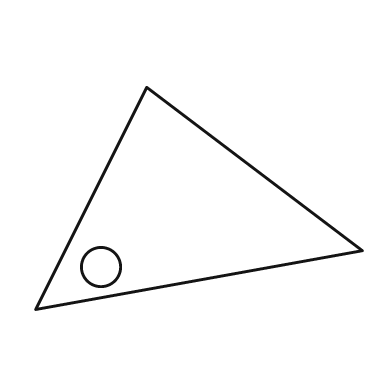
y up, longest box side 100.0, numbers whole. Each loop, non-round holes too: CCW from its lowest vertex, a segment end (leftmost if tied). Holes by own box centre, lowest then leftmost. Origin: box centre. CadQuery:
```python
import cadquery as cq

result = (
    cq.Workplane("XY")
    .moveTo(-50.0, -34.0)
    .lineTo(50.0, -16.0)
    .lineTo(-16.0, 34.0)
    .close()
    .moveTo(-30.0, -21.0)
    .circle(6.0)
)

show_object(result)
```